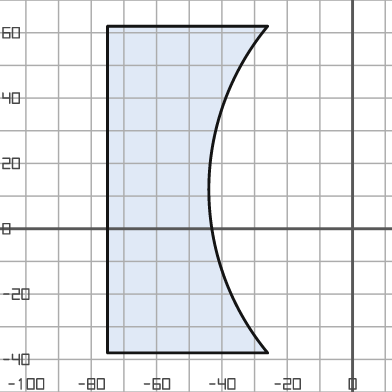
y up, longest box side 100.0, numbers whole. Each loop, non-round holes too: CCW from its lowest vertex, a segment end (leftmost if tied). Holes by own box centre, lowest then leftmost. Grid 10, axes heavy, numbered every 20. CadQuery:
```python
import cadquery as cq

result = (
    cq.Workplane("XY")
    .moveTo(-75.0, -38.0)
    .lineTo(-26.0, -38.0)
    .threePointArc((-44.0, 12.0), (-26.0, 62.0))
    .lineTo(-75.0, 62.0)
    .close()
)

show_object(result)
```